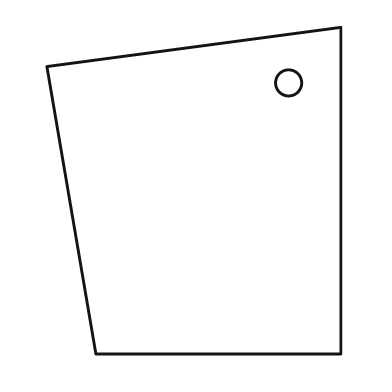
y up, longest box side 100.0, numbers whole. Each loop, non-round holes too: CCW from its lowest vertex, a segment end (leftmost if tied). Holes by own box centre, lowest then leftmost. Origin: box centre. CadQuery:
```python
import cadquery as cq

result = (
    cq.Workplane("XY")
    .moveTo(-30.0, -50.0)
    .lineTo(45.0, -50.0)
    .lineTo(45.0, 50.0)
    .lineTo(-45.0, 38.0)
    .close()
    .moveTo(29.0, 33.0)
    .circle(4.0)
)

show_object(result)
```